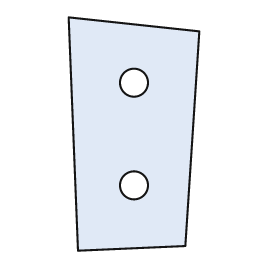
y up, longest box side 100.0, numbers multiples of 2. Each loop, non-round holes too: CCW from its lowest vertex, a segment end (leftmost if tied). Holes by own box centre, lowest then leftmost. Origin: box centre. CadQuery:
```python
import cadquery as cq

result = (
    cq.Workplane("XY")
    .moveTo(-24.0, -50.0)
    .lineTo(22.0, -48.0)
    .lineTo(28.0, 44.0)
    .lineTo(-28.0, 50.0)
    .close()
    .moveTo(0.0, -22.0)
    .circle(6.0)
    .moveTo(0.0, 22.0)
    .circle(6.0)
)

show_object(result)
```